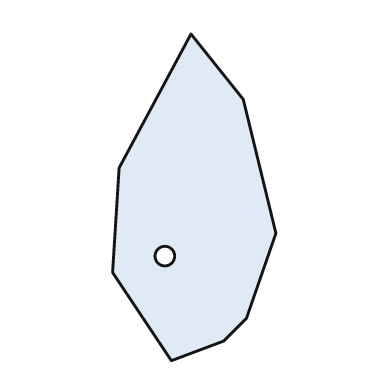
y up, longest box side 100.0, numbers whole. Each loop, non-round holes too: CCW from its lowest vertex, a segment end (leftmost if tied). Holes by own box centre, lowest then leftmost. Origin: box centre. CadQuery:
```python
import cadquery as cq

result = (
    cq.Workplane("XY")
    .moveTo(-7.0, -50.0)
    .lineTo(9.0, -44.0)
    .lineTo(16.0, -37.0)
    .lineTo(25.0, -11.0)
    .lineTo(15.0, 30.0)
    .lineTo(-1.0, 50.0)
    .lineTo(-23.0, 9.0)
    .lineTo(-25.0, -23.0)
    .close()
    .moveTo(-9.0, -18.0)
    .circle(3.0)
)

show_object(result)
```